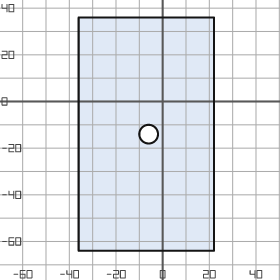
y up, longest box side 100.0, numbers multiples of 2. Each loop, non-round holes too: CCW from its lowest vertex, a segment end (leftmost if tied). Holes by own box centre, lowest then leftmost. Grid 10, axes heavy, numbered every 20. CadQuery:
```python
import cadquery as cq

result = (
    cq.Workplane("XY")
    .moveTo(-36.0, -64.0)
    .lineTo(22.0, -64.0)
    .lineTo(22.0, 36.0)
    .lineTo(-36.0, 36.0)
    .close()
    .moveTo(-6.0, -14.0)
    .circle(4.0)
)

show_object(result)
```